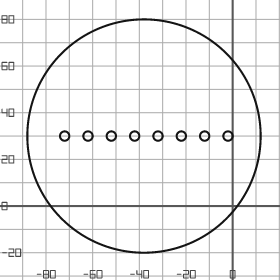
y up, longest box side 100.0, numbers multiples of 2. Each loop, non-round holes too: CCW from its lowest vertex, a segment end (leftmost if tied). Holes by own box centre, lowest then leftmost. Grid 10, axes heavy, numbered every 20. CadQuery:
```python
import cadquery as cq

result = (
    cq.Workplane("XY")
    .moveTo(-38.0, 30.0)
    .circle(50.0)
    .moveTo(-72.0, 30.0)
    .circle(2.0)
    .moveTo(-62.0, 30.0)
    .circle(2.0)
    .moveTo(-52.0, 30.0)
    .circle(2.0)
    .moveTo(-42.0, 30.0)
    .circle(2.0)
    .moveTo(-32.0, 30.0)
    .circle(2.0)
    .moveTo(-22.0, 30.0)
    .circle(2.0)
    .moveTo(-12.0, 30.0)
    .circle(2.0)
    .moveTo(-2.0, 30.0)
    .circle(2.0)
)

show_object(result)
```